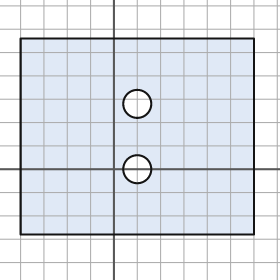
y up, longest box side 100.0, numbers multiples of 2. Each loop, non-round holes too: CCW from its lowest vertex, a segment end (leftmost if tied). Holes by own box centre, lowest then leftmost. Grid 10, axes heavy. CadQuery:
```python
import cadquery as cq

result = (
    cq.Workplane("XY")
    .moveTo(-40.0, -28.0)
    .lineTo(60.0, -28.0)
    .lineTo(60.0, 56.0)
    .lineTo(-40.0, 56.0)
    .close()
    .moveTo(10.0, 0.0)
    .circle(6.0)
    .moveTo(10.0, 28.0)
    .circle(6.0)
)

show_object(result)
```